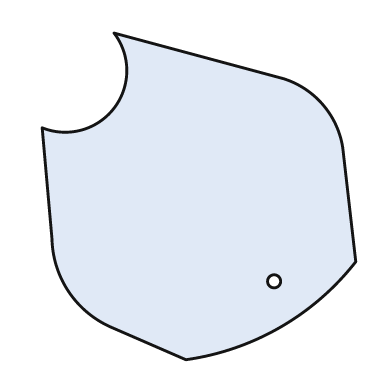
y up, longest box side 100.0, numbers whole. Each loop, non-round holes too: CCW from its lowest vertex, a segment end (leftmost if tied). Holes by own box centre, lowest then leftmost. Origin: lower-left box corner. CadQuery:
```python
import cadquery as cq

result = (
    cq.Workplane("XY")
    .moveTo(44.0, 0.0)
    .threePointArc((73.0, 10.0), (96.0, 30.0))
    .lineTo(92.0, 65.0)
    .threePointArc((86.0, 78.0), (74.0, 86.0))
    .lineTo(22.0, 100.0)
    .threePointArc((22.0, 77.0), (0.0, 71.0))
    .lineTo(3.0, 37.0)
    .threePointArc((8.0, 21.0), (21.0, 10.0))
    .close()
    .moveTo(71.0, 24.0)
    .circle(2.0)
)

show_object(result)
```